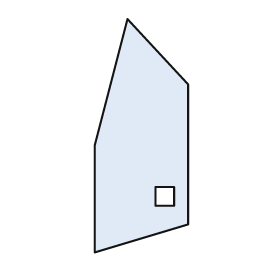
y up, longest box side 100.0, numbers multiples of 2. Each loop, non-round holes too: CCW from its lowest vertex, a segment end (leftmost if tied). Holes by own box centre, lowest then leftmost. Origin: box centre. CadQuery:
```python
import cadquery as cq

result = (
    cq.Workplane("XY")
    .moveTo(-20.0, -50.0)
    .lineTo(20.0, -38.0)
    .lineTo(20.0, 22.0)
    .lineTo(-6.0, 50.0)
    .lineTo(-20.0, -4.0)
    .close()
    .moveTo(6.0, -30.0)
    .lineTo(14.0, -30.0)
    .lineTo(14.0, -22.0)
    .lineTo(6.0, -22.0)
    .close()
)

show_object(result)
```